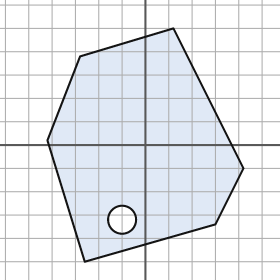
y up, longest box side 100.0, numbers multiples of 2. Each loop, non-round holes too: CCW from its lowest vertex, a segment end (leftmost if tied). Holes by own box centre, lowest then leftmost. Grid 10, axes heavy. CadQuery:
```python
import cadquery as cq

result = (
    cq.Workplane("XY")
    .moveTo(-26.0, -50.0)
    .lineTo(30.0, -34.0)
    .lineTo(42.0, -10.0)
    .lineTo(12.0, 50.0)
    .lineTo(-28.0, 38.0)
    .lineTo(-42.0, 2.0)
    .close()
    .moveTo(-10.0, -32.0)
    .circle(6.0)
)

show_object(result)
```